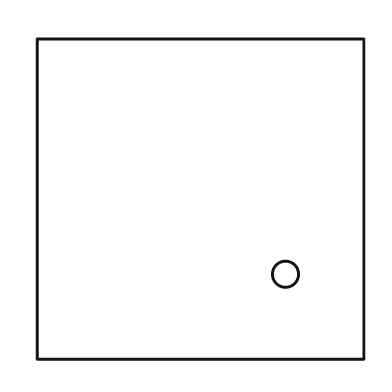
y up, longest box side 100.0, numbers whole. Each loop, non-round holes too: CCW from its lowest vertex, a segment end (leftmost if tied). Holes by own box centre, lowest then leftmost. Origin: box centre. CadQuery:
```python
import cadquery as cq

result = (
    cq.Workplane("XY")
    .moveTo(-50.0, -49.0)
    .lineTo(50.0, -49.0)
    .lineTo(50.0, 49.0)
    .lineTo(-50.0, 49.0)
    .close()
    .moveTo(26.0, -23.0)
    .circle(4.0)
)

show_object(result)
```